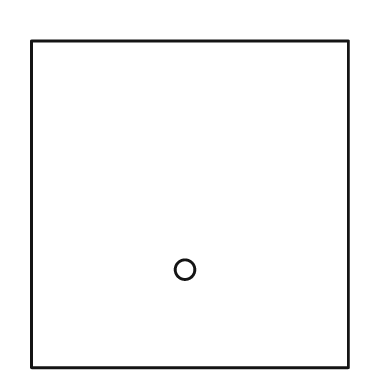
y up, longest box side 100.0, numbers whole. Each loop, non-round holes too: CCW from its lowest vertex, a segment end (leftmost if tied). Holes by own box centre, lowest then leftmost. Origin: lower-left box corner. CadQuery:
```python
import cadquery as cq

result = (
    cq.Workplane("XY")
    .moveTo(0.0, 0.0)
    .lineTo(97.0, 0.0)
    .lineTo(97.0, 100.0)
    .lineTo(0.0, 100.0)
    .close()
    .moveTo(47.0, 30.0)
    .circle(3.0)
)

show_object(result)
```